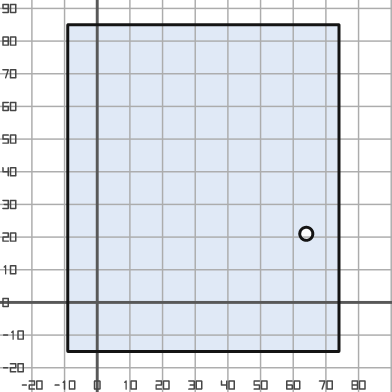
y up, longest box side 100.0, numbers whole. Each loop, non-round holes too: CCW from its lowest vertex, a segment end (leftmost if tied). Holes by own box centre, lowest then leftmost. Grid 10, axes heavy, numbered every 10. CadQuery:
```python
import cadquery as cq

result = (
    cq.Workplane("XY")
    .moveTo(-9.0, -15.0)
    .lineTo(74.0, -15.0)
    .lineTo(74.0, 85.0)
    .lineTo(-9.0, 85.0)
    .close()
    .moveTo(64.0, 21.0)
    .circle(2.0)
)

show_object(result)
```